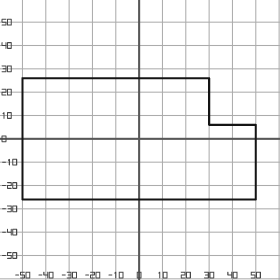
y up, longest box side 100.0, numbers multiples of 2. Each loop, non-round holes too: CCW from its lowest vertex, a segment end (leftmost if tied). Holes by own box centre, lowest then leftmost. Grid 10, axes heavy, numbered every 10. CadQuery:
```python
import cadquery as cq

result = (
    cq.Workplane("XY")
    .moveTo(-50.0, -26.0)
    .lineTo(50.0, -26.0)
    .lineTo(50.0, 6.0)
    .lineTo(30.0, 6.0)
    .lineTo(30.0, 26.0)
    .lineTo(-50.0, 26.0)
    .close()
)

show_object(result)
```